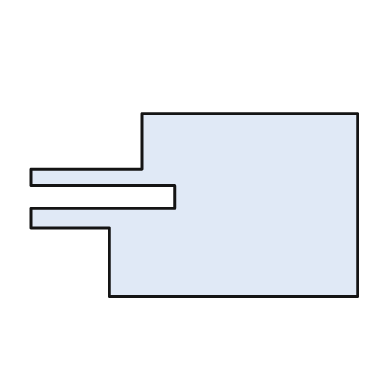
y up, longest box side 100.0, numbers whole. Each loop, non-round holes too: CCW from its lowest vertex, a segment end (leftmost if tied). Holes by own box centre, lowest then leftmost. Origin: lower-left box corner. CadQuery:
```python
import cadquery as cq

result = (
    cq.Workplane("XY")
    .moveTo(24.0, 0.0)
    .lineTo(100.0, 0.0)
    .lineTo(100.0, 56.0)
    .lineTo(34.0, 56.0)
    .lineTo(34.0, 39.0)
    .lineTo(0.0, 39.0)
    .lineTo(0.0, 34.0)
    .lineTo(44.0, 34.0)
    .lineTo(44.0, 27.0)
    .lineTo(0.0, 27.0)
    .lineTo(0.0, 21.0)
    .lineTo(24.0, 21.0)
    .close()
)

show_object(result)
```